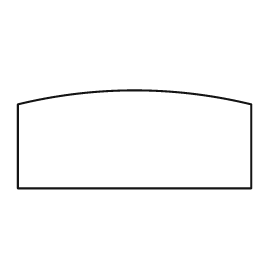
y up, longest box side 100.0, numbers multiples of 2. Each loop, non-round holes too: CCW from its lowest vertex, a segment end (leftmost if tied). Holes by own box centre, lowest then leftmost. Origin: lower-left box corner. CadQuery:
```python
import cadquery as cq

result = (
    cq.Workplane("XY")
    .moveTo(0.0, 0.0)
    .lineTo(100.0, 0.0)
    .lineTo(100.0, 36.0)
    .threePointArc((50.0, 42.0), (0.0, 36.0))
    .close()
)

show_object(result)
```